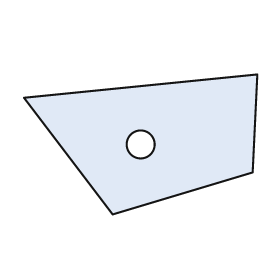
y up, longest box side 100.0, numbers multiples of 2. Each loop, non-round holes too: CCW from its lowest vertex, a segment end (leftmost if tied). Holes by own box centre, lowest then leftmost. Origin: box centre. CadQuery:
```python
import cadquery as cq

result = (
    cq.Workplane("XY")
    .moveTo(-12.0, -30.0)
    .lineTo(48.0, -12.0)
    .lineTo(50.0, 30.0)
    .lineTo(-50.0, 20.0)
    .close()
    .moveTo(0.0, 0.0)
    .circle(6.0)
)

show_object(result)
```